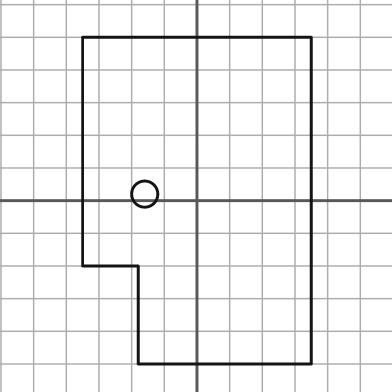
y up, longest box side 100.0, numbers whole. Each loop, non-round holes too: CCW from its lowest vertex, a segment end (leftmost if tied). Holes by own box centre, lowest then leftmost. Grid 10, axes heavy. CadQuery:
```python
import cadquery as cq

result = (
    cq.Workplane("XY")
    .moveTo(-18.0, -50.0)
    .lineTo(35.0, -50.0)
    .lineTo(35.0, 50.0)
    .lineTo(-35.0, 50.0)
    .lineTo(-35.0, -20.0)
    .lineTo(-18.0, -20.0)
    .close()
    .moveTo(-16.0, 2.0)
    .circle(4.0)
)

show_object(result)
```